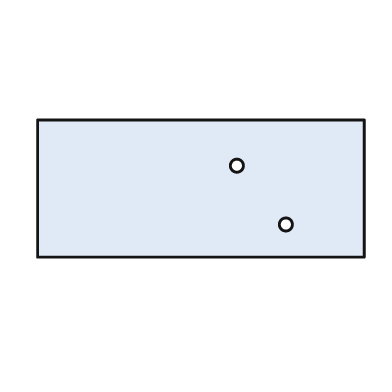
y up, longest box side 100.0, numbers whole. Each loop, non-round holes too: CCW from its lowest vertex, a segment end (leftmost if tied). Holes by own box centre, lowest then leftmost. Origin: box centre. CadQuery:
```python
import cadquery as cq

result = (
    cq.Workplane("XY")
    .moveTo(-50.0, -21.0)
    .lineTo(50.0, -21.0)
    .lineTo(50.0, 21.0)
    .lineTo(-50.0, 21.0)
    .close()
    .moveTo(26.0, -11.0)
    .circle(2.0)
    .moveTo(11.0, 7.0)
    .circle(2.0)
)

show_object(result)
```